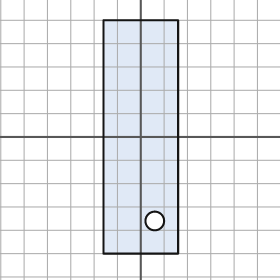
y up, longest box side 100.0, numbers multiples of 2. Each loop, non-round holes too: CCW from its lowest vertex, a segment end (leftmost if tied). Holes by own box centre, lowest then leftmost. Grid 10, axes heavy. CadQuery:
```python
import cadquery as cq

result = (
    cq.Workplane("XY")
    .moveTo(-16.0, -50.0)
    .lineTo(16.0, -50.0)
    .lineTo(16.0, 50.0)
    .lineTo(-16.0, 50.0)
    .close()
    .moveTo(6.0, -36.0)
    .circle(4.0)
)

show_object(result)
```